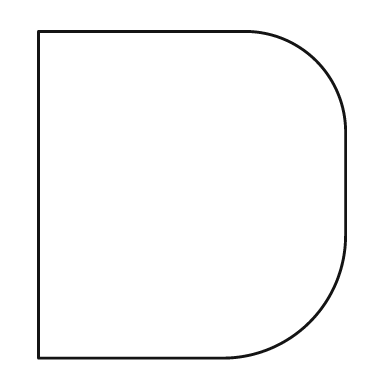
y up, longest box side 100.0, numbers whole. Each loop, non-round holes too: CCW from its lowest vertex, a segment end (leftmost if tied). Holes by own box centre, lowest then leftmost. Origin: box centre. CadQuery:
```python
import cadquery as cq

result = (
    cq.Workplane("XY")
    .moveTo(-47.0, -50.0)
    .lineTo(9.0, -50.0)
    .threePointArc((36.0, -39.0), (47.0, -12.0))
    .lineTo(47.0, 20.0)
    .threePointArc((38.0, 41.0), (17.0, 50.0))
    .lineTo(-47.0, 50.0)
    .close()
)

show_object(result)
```